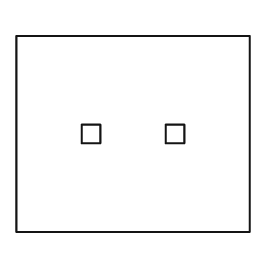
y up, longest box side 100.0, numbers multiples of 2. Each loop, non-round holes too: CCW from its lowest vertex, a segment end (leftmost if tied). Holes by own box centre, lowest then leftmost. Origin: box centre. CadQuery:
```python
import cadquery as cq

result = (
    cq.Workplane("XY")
    .moveTo(-50.0, -42.0)
    .lineTo(50.0, -42.0)
    .lineTo(50.0, 42.0)
    .lineTo(-50.0, 42.0)
    .close()
    .moveTo(-22.0, -4.0)
    .lineTo(-14.0, -4.0)
    .lineTo(-14.0, 4.0)
    .lineTo(-22.0, 4.0)
    .close()
    .moveTo(14.0, -4.0)
    .lineTo(22.0, -4.0)
    .lineTo(22.0, 4.0)
    .lineTo(14.0, 4.0)
    .close()
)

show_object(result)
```